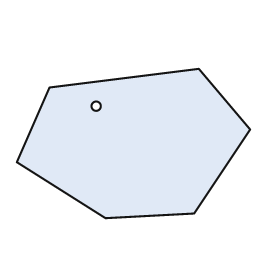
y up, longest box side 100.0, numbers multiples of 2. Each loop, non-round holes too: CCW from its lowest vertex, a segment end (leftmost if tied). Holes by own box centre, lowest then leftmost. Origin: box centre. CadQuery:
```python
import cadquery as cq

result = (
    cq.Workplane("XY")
    .moveTo(-12.0, -32.0)
    .lineTo(26.0, -30.0)
    .lineTo(50.0, 6.0)
    .lineTo(28.0, 32.0)
    .lineTo(-36.0, 24.0)
    .lineTo(-50.0, -8.0)
    .close()
    .moveTo(-16.0, 16.0)
    .circle(2.0)
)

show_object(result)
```